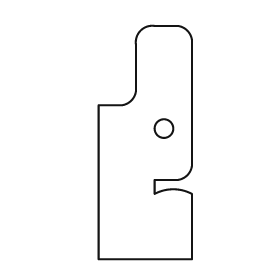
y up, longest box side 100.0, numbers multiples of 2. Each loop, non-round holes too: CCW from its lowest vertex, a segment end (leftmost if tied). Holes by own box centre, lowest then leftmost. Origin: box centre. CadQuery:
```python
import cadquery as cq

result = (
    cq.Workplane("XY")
    .moveTo(-20.0, -50.0)
    .lineTo(20.0, -50.0)
    .lineTo(20.0, -22.0)
    .threePointArc((12.0, -20.0), (4.0, -22.0))
    .lineTo(4.0, -16.0)
    .lineTo(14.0, -16.0)
    .threePointArc((18.0, -14.0), (20.0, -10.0))
    .lineTo(20.0, 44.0)
    .threePointArc((18.0, 48.0), (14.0, 50.0))
    .lineTo(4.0, 50.0)
    .threePointArc((-2.0, 48.0), (-4.0, 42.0))
    .lineTo(-4.0, 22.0)
    .threePointArc((-6.0, 18.0), (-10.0, 16.0))
    .lineTo(-20.0, 16.0)
    .close()
    .moveTo(8.0, 6.0)
    .circle(4.0)
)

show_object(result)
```